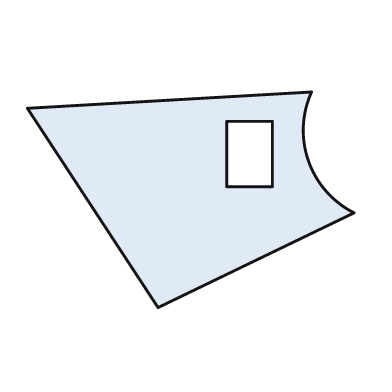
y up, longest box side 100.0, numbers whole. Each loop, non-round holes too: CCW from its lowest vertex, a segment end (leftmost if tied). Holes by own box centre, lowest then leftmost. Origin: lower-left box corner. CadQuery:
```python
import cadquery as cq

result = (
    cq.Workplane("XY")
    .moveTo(40.0, 0.0)
    .lineTo(100.0, 29.0)
    .threePointArc((86.0, 45.0), (87.0, 66.0))
    .lineTo(0.0, 61.0)
    .close()
    .moveTo(61.0, 37.0)
    .lineTo(75.0, 37.0)
    .lineTo(75.0, 57.0)
    .lineTo(61.0, 57.0)
    .close()
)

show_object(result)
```